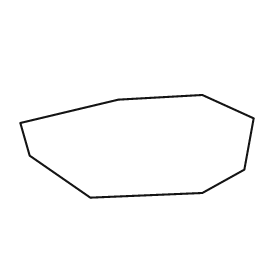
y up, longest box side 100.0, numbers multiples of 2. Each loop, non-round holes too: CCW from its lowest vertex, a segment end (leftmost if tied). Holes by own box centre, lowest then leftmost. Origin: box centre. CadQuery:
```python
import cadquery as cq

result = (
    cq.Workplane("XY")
    .moveTo(-20.0, -22.0)
    .lineTo(28.0, -20.0)
    .lineTo(46.0, -10.0)
    .lineTo(50.0, 12.0)
    .lineTo(28.0, 22.0)
    .lineTo(-8.0, 20.0)
    .lineTo(-50.0, 10.0)
    .lineTo(-46.0, -4.0)
    .close()
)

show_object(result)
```